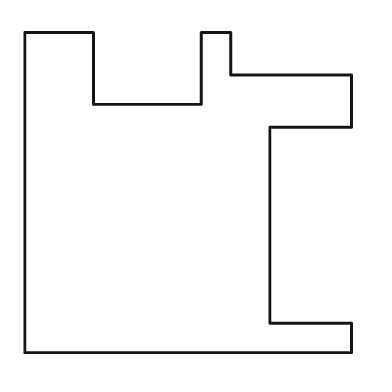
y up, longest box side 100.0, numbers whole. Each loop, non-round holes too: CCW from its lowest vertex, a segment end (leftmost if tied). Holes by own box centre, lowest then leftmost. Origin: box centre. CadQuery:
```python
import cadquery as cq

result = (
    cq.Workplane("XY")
    .moveTo(-50.0, -49.0)
    .lineTo(50.0, -49.0)
    .lineTo(50.0, -40.0)
    .lineTo(25.0, -40.0)
    .lineTo(25.0, 20.0)
    .lineTo(50.0, 20.0)
    .lineTo(50.0, 36.0)
    .lineTo(13.0, 36.0)
    .lineTo(13.0, 49.0)
    .lineTo(4.0, 49.0)
    .lineTo(4.0, 27.0)
    .lineTo(-29.0, 27.0)
    .lineTo(-29.0, 49.0)
    .lineTo(-50.0, 49.0)
    .close()
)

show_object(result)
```